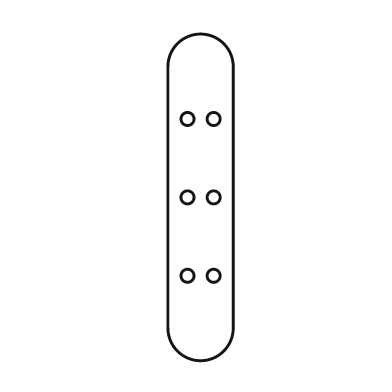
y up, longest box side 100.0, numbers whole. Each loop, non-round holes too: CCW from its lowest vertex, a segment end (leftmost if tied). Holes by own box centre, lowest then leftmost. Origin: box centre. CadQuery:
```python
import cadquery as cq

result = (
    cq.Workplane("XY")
    .moveTo(-10.0, -40.0)
    .threePointArc((0.0, -50.0), (10.0, -40.0))
    .lineTo(10.0, 40.0)
    .threePointArc((0.0, 50.0), (-10.0, 40.0))
    .close()
    .moveTo(-4.0, -24.0)
    .circle(2.0)
    .moveTo(4.0, -24.0)
    .circle(2.0)
    .moveTo(-4.0, 0.0)
    .circle(2.0)
    .moveTo(4.0, 0.0)
    .circle(2.0)
    .moveTo(-4.0, 24.0)
    .circle(2.0)
    .moveTo(4.0, 24.0)
    .circle(2.0)
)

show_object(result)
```